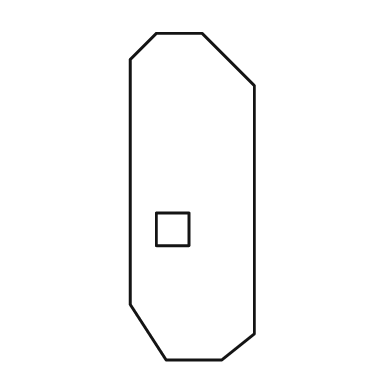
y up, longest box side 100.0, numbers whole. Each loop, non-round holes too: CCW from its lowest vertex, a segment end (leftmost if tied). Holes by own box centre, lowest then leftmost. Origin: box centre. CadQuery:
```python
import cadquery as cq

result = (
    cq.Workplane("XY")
    .moveTo(-8.0, -50.0)
    .lineTo(9.0, -50.0)
    .lineTo(19.0, -42.0)
    .lineTo(19.0, 34.0)
    .lineTo(3.0, 50.0)
    .lineTo(-11.0, 50.0)
    .lineTo(-19.0, 42.0)
    .lineTo(-19.0, -33.0)
    .close()
    .moveTo(-11.0, -15.0)
    .lineTo(-1.0, -15.0)
    .lineTo(-1.0, -5.0)
    .lineTo(-11.0, -5.0)
    .close()
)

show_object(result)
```